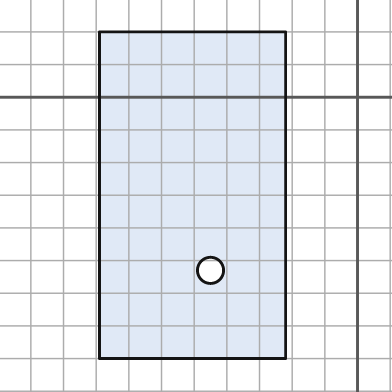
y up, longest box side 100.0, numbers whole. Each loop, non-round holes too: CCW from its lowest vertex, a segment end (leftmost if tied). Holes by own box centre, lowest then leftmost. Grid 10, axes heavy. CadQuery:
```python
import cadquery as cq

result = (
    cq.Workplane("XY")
    .moveTo(-79.0, -80.0)
    .lineTo(-22.0, -80.0)
    .lineTo(-22.0, 20.0)
    .lineTo(-79.0, 20.0)
    .close()
    .moveTo(-45.0, -53.0)
    .circle(4.0)
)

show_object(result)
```